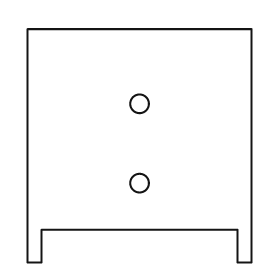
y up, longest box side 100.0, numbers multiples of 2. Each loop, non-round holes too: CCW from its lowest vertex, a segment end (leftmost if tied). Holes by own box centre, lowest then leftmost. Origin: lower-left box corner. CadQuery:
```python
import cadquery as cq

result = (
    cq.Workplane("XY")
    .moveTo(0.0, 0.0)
    .lineTo(6.0, 0.0)
    .lineTo(6.0, 14.0)
    .lineTo(90.0, 14.0)
    .lineTo(90.0, 0.0)
    .lineTo(96.0, 0.0)
    .lineTo(96.0, 100.0)
    .lineTo(0.0, 100.0)
    .close()
    .moveTo(48.0, 34.0)
    .circle(4.0)
    .moveTo(48.0, 68.0)
    .circle(4.0)
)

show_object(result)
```